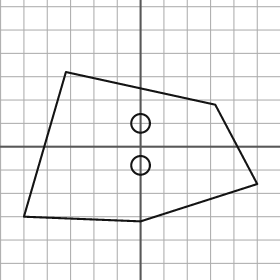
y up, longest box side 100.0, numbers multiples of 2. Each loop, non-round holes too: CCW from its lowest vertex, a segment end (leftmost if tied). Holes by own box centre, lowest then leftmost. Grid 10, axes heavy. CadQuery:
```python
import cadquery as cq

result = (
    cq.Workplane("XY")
    .moveTo(0.0, -32.0)
    .lineTo(50.0, -16.0)
    .lineTo(32.0, 18.0)
    .lineTo(-32.0, 32.0)
    .lineTo(-50.0, -30.0)
    .close()
    .moveTo(0.0, -8.0)
    .circle(4.0)
    .moveTo(0.0, 10.0)
    .circle(4.0)
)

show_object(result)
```